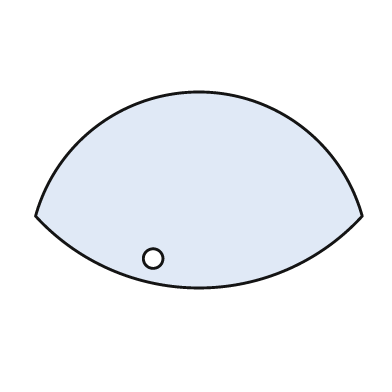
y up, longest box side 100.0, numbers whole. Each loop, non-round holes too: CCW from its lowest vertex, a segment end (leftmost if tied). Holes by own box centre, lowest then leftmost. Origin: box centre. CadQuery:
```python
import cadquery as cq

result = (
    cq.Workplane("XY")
    .moveTo(-50.0, -8.0)
    .threePointArc((0.0, -30.0), (50.0, -8.0))
    .threePointArc((0.0, 30.0), (-50.0, -8.0))
    .close()
    .moveTo(-14.0, -21.0)
    .circle(3.0)
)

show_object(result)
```